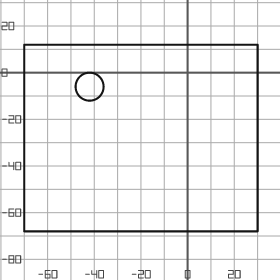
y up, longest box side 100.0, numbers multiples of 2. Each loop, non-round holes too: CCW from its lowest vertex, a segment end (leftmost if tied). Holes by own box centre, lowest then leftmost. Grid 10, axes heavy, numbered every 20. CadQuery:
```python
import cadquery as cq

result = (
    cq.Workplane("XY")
    .moveTo(-70.0, -68.0)
    .lineTo(30.0, -68.0)
    .lineTo(30.0, 12.0)
    .lineTo(-70.0, 12.0)
    .close()
    .moveTo(-42.0, -6.0)
    .circle(6.0)
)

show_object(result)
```